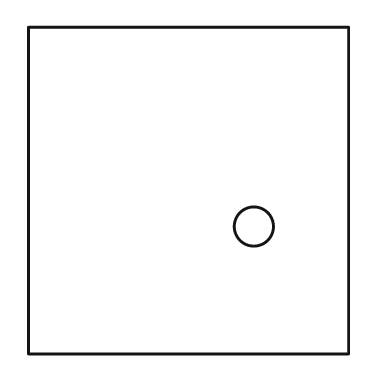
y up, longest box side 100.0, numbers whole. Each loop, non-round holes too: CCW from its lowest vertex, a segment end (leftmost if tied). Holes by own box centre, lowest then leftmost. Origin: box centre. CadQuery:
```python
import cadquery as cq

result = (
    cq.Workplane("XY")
    .moveTo(-49.0, -50.0)
    .lineTo(49.0, -50.0)
    .lineTo(49.0, 50.0)
    .lineTo(-49.0, 50.0)
    .close()
    .moveTo(20.0, -11.0)
    .circle(6.0)
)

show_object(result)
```